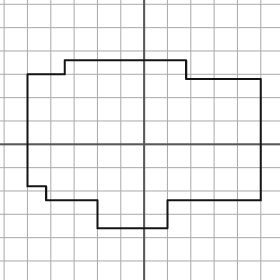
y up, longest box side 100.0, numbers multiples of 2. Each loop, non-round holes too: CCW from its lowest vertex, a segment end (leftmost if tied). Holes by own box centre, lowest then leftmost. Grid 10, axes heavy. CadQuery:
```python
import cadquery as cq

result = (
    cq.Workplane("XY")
    .moveTo(-20.0, -36.0)
    .lineTo(10.0, -36.0)
    .lineTo(10.0, -24.0)
    .lineTo(50.0, -24.0)
    .lineTo(50.0, 28.0)
    .lineTo(18.0, 28.0)
    .lineTo(18.0, 36.0)
    .lineTo(-34.0, 36.0)
    .lineTo(-34.0, 30.0)
    .lineTo(-50.0, 30.0)
    .lineTo(-50.0, -18.0)
    .lineTo(-42.0, -18.0)
    .lineTo(-42.0, -24.0)
    .lineTo(-20.0, -24.0)
    .close()
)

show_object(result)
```